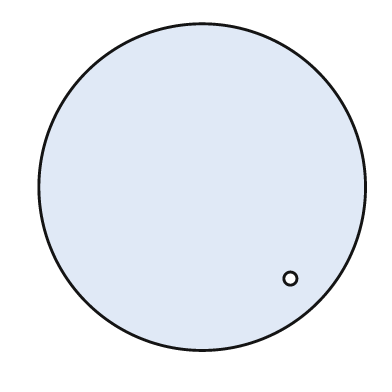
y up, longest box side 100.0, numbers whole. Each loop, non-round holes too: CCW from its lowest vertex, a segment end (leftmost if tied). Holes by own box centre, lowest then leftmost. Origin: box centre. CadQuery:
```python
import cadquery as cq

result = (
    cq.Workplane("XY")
    .moveTo(0.0, 0.0)
    .circle(50.0)
    .moveTo(27.0, -28.0)
    .circle(2.0)
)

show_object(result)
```